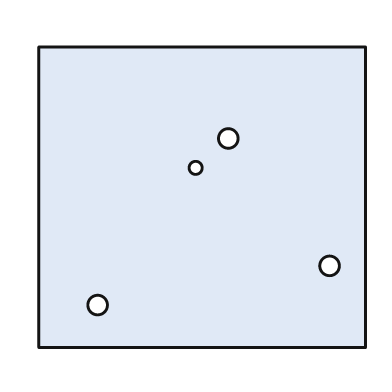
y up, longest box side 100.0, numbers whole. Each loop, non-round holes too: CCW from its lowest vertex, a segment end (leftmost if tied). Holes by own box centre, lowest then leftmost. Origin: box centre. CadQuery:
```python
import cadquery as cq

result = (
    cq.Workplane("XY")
    .moveTo(-50.0, -46.0)
    .lineTo(50.0, -46.0)
    .lineTo(50.0, 46.0)
    .lineTo(-50.0, 46.0)
    .close()
    .moveTo(-32.0, -33.0)
    .circle(3.0)
    .moveTo(39.0, -21.0)
    .circle(3.0)
    .moveTo(-2.0, 9.0)
    .circle(2.0)
    .moveTo(8.0, 18.0)
    .circle(3.0)
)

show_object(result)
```